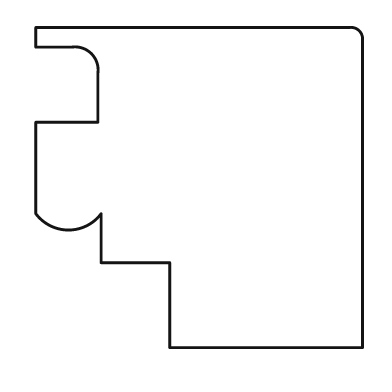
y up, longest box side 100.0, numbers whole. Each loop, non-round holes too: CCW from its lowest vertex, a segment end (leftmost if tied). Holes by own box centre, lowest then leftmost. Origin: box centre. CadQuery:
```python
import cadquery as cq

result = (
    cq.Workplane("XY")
    .moveTo(-9.0, -49.0)
    .lineTo(50.0, -49.0)
    .lineTo(50.0, 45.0)
    .threePointArc((49.0, 48.0), (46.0, 49.0))
    .lineTo(-50.0, 49.0)
    .lineTo(-50.0, 43.0)
    .lineTo(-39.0, 43.0)
    .threePointArc((-33.0, 41.0), (-31.0, 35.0))
    .lineTo(-31.0, 20.0)
    .lineTo(-50.0, 20.0)
    .lineTo(-50.0, -8.0)
    .threePointArc((-40.0, -13.0), (-30.0, -8.0))
    .lineTo(-30.0, -23.0)
    .lineTo(-9.0, -23.0)
    .close()
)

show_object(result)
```